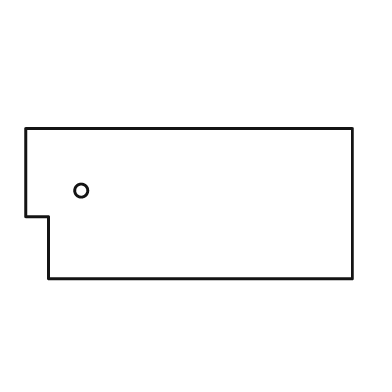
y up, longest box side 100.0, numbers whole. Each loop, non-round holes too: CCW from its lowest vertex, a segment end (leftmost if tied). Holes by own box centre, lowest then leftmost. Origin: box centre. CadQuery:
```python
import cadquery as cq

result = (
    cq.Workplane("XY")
    .moveTo(-43.0, -23.0)
    .lineTo(50.0, -23.0)
    .lineTo(50.0, 23.0)
    .lineTo(-50.0, 23.0)
    .lineTo(-50.0, -4.0)
    .lineTo(-43.0, -4.0)
    .close()
    .moveTo(-33.0, 4.0)
    .circle(2.0)
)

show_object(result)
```